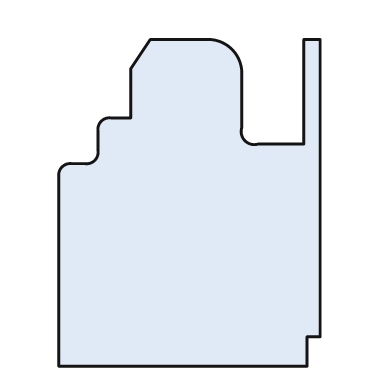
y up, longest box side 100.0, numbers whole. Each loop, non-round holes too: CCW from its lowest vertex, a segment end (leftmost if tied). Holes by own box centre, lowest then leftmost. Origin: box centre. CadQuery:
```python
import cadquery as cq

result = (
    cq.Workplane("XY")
    .moveTo(-40.0, -50.0)
    .lineTo(36.0, -50.0)
    .lineTo(36.0, -41.0)
    .lineTo(40.0, -41.0)
    .lineTo(40.0, 50.0)
    .lineTo(35.0, 50.0)
    .lineTo(35.0, 18.0)
    .lineTo(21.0, 18.0)
    .threePointArc((17.0, 19.0), (16.0, 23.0))
    .lineTo(16.0, 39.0)
    .threePointArc((13.0, 47.0), (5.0, 50.0))
    .lineTo(-12.0, 50.0)
    .lineTo(-18.0, 41.0)
    .lineTo(-18.0, 26.0)
    .lineTo(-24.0, 26.0)
    .threePointArc((-27.0, 25.0), (-28.0, 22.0))
    .lineTo(-28.0, 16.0)
    .threePointArc((-29.0, 13.0), (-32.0, 12.0))
    .lineTo(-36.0, 12.0)
    .threePointArc((-39.0, 11.0), (-40.0, 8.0))
    .close()
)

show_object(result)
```